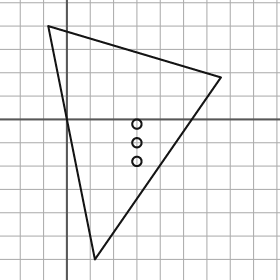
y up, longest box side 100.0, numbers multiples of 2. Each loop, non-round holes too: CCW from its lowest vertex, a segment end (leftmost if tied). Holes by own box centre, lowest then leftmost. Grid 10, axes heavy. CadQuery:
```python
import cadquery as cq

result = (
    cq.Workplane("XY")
    .moveTo(12.0, -60.0)
    .lineTo(66.0, 18.0)
    .lineTo(-8.0, 40.0)
    .close()
    .moveTo(30.0, -18.0)
    .circle(2.0)
    .moveTo(30.0, -10.0)
    .circle(2.0)
    .moveTo(30.0, -2.0)
    .circle(2.0)
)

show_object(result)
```